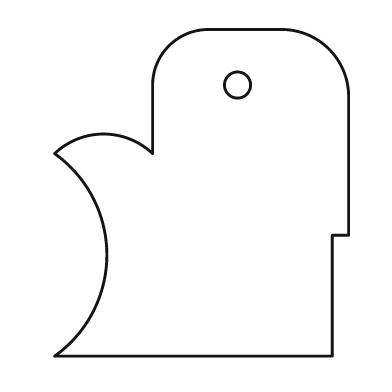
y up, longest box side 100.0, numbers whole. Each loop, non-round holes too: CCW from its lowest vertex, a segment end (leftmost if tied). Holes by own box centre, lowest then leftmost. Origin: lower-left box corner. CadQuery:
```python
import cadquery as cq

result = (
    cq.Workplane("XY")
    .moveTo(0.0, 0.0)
    .lineTo(85.0, 0.0)
    .lineTo(85.0, 37.0)
    .lineTo(90.0, 37.0)
    .lineTo(90.0, 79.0)
    .threePointArc((84.0, 94.0), (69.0, 100.0))
    .lineTo(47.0, 100.0)
    .threePointArc((35.0, 95.0), (30.0, 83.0))
    .lineTo(30.0, 62.0)
    .threePointArc((15.0, 68.0), (0.0, 62.0))
    .threePointArc((16.0, 31.0), (0.0, 0.0))
    .close()
    .moveTo(56.0, 83.0)
    .circle(4.0)
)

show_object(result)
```